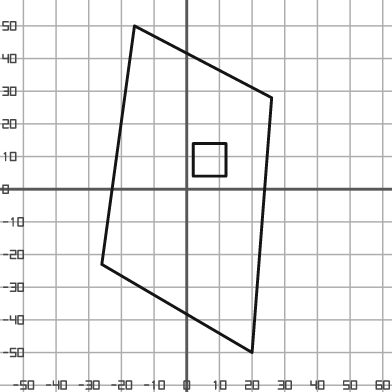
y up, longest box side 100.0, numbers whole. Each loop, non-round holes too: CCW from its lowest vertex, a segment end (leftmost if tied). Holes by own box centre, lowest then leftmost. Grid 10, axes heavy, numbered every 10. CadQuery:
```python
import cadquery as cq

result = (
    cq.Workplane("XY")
    .moveTo(20.0, -50.0)
    .lineTo(26.0, 28.0)
    .lineTo(-16.0, 50.0)
    .lineTo(-26.0, -23.0)
    .close()
    .moveTo(2.0, 4.0)
    .lineTo(12.0, 4.0)
    .lineTo(12.0, 14.0)
    .lineTo(2.0, 14.0)
    .close()
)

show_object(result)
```